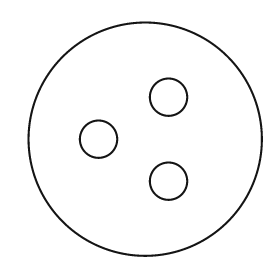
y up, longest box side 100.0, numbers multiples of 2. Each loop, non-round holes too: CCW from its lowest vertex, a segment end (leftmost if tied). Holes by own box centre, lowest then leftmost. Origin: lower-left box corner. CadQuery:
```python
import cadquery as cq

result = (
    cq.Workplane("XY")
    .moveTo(50.0, 50.0)
    .circle(50.0)
    .moveTo(60.0, 32.0)
    .circle(8.0)
    .moveTo(30.0, 50.0)
    .circle(8.0)
    .moveTo(60.0, 68.0)
    .circle(8.0)
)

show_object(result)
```